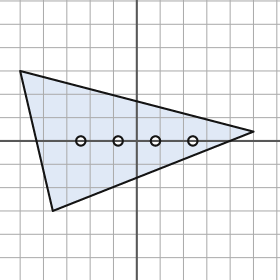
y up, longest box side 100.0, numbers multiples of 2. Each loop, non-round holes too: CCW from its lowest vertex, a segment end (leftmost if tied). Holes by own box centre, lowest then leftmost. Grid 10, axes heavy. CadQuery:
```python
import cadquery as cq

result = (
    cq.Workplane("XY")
    .moveTo(-36.0, -30.0)
    .lineTo(50.0, 4.0)
    .lineTo(-50.0, 30.0)
    .close()
    .moveTo(-24.0, 0.0)
    .circle(2.0)
    .moveTo(-8.0, 0.0)
    .circle(2.0)
    .moveTo(8.0, 0.0)
    .circle(2.0)
    .moveTo(24.0, 0.0)
    .circle(2.0)
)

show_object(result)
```